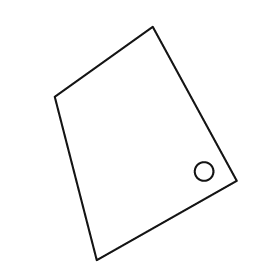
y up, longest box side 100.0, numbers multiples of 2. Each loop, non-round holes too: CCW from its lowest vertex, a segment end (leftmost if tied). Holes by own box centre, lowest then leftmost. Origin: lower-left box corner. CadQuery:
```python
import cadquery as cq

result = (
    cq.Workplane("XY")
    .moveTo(18.0, 0.0)
    .lineTo(78.0, 34.0)
    .lineTo(42.0, 100.0)
    .lineTo(0.0, 70.0)
    .close()
    .moveTo(64.0, 38.0)
    .circle(4.0)
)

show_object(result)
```